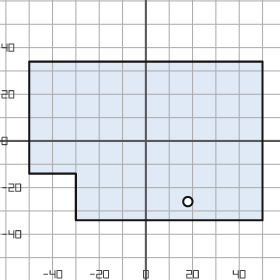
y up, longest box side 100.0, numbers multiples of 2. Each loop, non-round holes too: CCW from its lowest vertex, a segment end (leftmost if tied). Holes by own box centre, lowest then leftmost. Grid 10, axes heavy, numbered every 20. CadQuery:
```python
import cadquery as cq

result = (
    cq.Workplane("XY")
    .moveTo(-30.0, -34.0)
    .lineTo(50.0, -34.0)
    .lineTo(50.0, 34.0)
    .lineTo(-50.0, 34.0)
    .lineTo(-50.0, -14.0)
    .lineTo(-30.0, -14.0)
    .close()
    .moveTo(18.0, -26.0)
    .circle(2.0)
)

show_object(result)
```